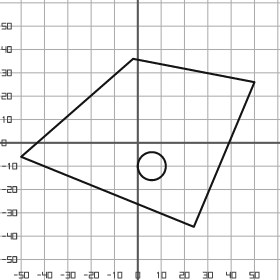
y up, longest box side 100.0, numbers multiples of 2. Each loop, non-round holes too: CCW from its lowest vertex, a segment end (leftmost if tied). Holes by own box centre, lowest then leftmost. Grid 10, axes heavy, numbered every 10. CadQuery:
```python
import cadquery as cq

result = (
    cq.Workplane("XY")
    .moveTo(24.0, -36.0)
    .lineTo(50.0, 26.0)
    .lineTo(-2.0, 36.0)
    .lineTo(-50.0, -6.0)
    .close()
    .moveTo(6.0, -10.0)
    .circle(6.0)
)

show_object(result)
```